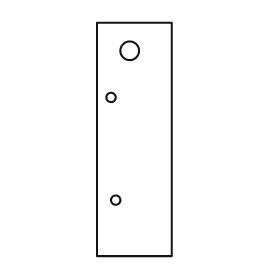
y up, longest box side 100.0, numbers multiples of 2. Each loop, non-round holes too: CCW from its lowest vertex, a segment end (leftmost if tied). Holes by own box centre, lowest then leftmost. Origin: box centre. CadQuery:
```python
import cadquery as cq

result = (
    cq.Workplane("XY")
    .moveTo(-16.0, -50.0)
    .lineTo(16.0, -50.0)
    .lineTo(16.0, 50.0)
    .lineTo(-16.0, 50.0)
    .close()
    .moveTo(-8.0, -26.0)
    .circle(2.0)
    .moveTo(-10.0, 18.0)
    .circle(2.0)
    .moveTo(-2.0, 38.0)
    .circle(4.0)
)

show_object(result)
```